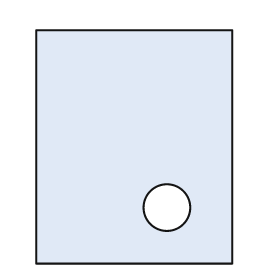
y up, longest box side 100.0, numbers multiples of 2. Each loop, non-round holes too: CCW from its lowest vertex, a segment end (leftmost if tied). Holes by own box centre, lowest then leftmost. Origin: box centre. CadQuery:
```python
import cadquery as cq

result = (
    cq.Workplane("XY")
    .moveTo(-42.0, -50.0)
    .lineTo(42.0, -50.0)
    .lineTo(42.0, 50.0)
    .lineTo(-42.0, 50.0)
    .close()
    .moveTo(14.0, -26.0)
    .circle(10.0)
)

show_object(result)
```